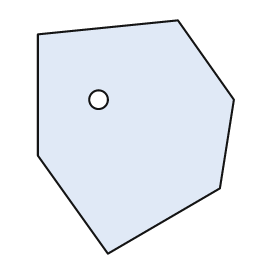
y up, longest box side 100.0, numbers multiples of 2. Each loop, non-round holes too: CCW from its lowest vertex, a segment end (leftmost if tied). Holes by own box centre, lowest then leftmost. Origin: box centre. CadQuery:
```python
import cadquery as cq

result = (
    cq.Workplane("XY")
    .moveTo(-12.0, -50.0)
    .lineTo(36.0, -22.0)
    .lineTo(42.0, 16.0)
    .lineTo(18.0, 50.0)
    .lineTo(-42.0, 44.0)
    .lineTo(-42.0, -8.0)
    .close()
    .moveTo(-16.0, 16.0)
    .circle(4.0)
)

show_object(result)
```